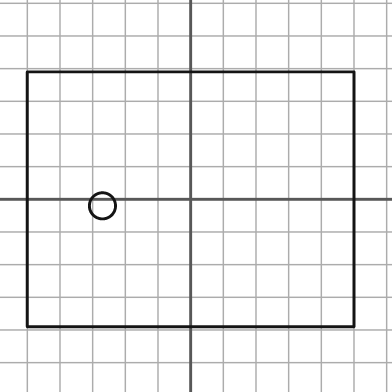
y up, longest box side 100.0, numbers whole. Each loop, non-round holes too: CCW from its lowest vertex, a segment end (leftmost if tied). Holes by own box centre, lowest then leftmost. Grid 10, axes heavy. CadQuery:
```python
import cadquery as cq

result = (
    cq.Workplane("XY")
    .moveTo(-50.0, -39.0)
    .lineTo(50.0, -39.0)
    .lineTo(50.0, 39.0)
    .lineTo(-50.0, 39.0)
    .close()
    .moveTo(-27.0, -2.0)
    .circle(4.0)
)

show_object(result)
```